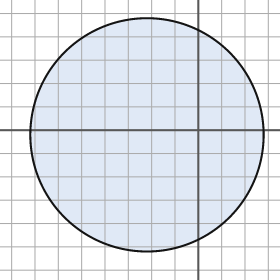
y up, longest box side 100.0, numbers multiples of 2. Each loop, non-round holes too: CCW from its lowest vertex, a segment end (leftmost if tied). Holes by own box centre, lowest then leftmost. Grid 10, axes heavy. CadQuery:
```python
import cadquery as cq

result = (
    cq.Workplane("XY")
    .moveTo(-22.0, -2.0)
    .circle(50.0)
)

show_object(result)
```